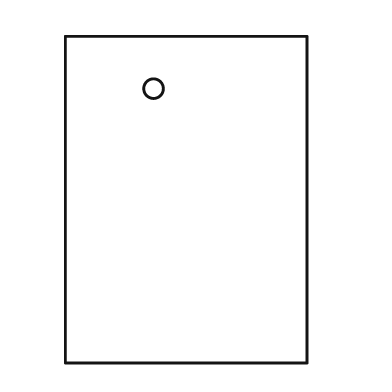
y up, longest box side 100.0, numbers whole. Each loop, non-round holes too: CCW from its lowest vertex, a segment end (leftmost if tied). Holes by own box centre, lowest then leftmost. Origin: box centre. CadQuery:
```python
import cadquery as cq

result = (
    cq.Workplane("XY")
    .moveTo(-37.0, -50.0)
    .lineTo(37.0, -50.0)
    .lineTo(37.0, 50.0)
    .lineTo(-37.0, 50.0)
    .close()
    .moveTo(-10.0, 34.0)
    .circle(3.0)
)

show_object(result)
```